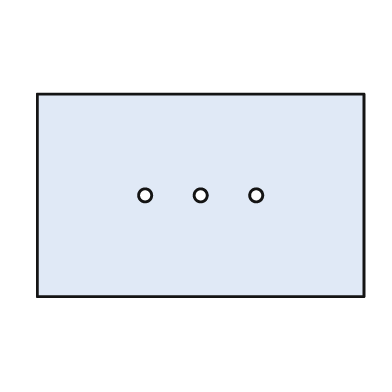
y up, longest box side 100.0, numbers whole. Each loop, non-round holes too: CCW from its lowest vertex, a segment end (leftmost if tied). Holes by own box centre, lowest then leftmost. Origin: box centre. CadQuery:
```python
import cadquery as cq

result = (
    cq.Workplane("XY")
    .moveTo(-50.0, -31.0)
    .lineTo(50.0, -31.0)
    .lineTo(50.0, 31.0)
    .lineTo(-50.0, 31.0)
    .close()
    .moveTo(-17.0, 0.0)
    .circle(2.0)
    .moveTo(0.0, 0.0)
    .circle(2.0)
    .moveTo(17.0, 0.0)
    .circle(2.0)
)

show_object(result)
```